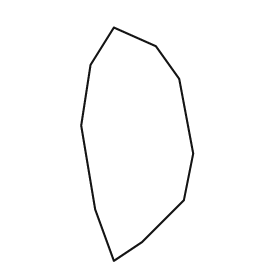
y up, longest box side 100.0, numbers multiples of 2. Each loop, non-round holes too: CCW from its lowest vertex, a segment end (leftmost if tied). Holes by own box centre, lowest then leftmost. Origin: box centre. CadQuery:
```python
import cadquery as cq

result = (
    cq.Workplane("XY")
    .moveTo(-10.0, -50.0)
    .lineTo(2.0, -42.0)
    .lineTo(20.0, -24.0)
    .lineTo(24.0, -4.0)
    .lineTo(18.0, 28.0)
    .lineTo(8.0, 42.0)
    .lineTo(-10.0, 50.0)
    .lineTo(-20.0, 34.0)
    .lineTo(-24.0, 8.0)
    .lineTo(-18.0, -28.0)
    .close()
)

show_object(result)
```